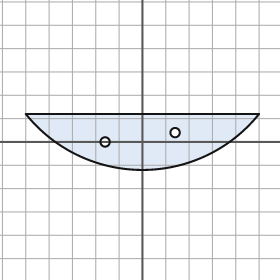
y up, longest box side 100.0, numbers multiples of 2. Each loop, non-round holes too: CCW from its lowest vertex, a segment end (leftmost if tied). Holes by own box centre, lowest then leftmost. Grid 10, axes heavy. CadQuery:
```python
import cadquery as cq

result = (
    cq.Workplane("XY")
    .moveTo(-50.0, 12.0)
    .threePointArc((0.0, -12.0), (50.0, 12.0))
    .close()
    .moveTo(-16.0, 0.0)
    .circle(2.0)
    .moveTo(14.0, 4.0)
    .circle(2.0)
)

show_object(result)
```